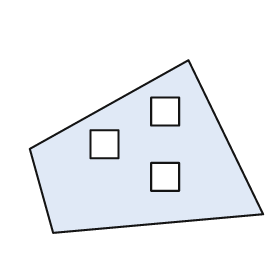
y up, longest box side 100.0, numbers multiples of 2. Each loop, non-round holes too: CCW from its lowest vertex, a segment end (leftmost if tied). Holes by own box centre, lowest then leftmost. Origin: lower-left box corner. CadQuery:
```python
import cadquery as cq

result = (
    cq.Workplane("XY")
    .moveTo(10.0, 0.0)
    .lineTo(100.0, 8.0)
    .lineTo(68.0, 74.0)
    .lineTo(0.0, 36.0)
    .close()
    .moveTo(52.0, 18.0)
    .lineTo(64.0, 18.0)
    .lineTo(64.0, 30.0)
    .lineTo(52.0, 30.0)
    .close()
    .moveTo(26.0, 32.0)
    .lineTo(38.0, 32.0)
    .lineTo(38.0, 44.0)
    .lineTo(26.0, 44.0)
    .close()
    .moveTo(52.0, 46.0)
    .lineTo(64.0, 46.0)
    .lineTo(64.0, 58.0)
    .lineTo(52.0, 58.0)
    .close()
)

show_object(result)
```